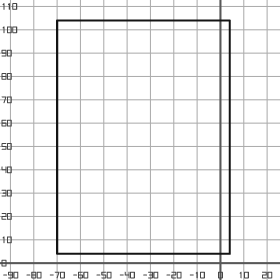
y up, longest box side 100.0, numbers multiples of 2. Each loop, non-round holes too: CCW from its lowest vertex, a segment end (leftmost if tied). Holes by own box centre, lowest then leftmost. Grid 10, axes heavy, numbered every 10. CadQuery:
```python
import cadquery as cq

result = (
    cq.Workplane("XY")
    .moveTo(-70.0, 4.0)
    .lineTo(4.0, 4.0)
    .lineTo(4.0, 104.0)
    .lineTo(-70.0, 104.0)
    .close()
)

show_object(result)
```